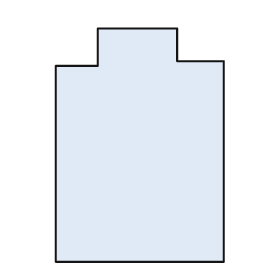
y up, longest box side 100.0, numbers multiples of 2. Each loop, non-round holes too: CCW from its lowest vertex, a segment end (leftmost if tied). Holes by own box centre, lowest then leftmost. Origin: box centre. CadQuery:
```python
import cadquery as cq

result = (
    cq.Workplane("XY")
    .moveTo(-36.0, -50.0)
    .lineTo(36.0, -50.0)
    .lineTo(36.0, 36.0)
    .lineTo(16.0, 36.0)
    .lineTo(16.0, 50.0)
    .lineTo(-18.0, 50.0)
    .lineTo(-18.0, 34.0)
    .lineTo(-36.0, 34.0)
    .close()
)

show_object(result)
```